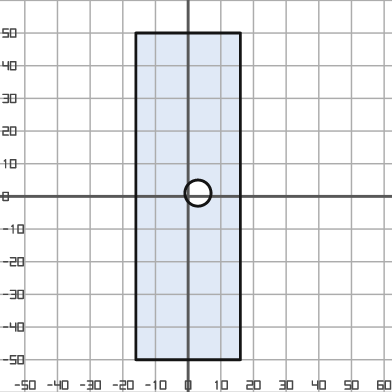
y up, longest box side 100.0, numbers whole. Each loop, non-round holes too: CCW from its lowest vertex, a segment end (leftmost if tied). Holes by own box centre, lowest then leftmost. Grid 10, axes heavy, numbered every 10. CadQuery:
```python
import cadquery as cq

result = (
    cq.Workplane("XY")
    .moveTo(-16.0, -50.0)
    .lineTo(16.0, -50.0)
    .lineTo(16.0, 50.0)
    .lineTo(-16.0, 50.0)
    .close()
    .moveTo(3.0, 1.0)
    .circle(4.0)
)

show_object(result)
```